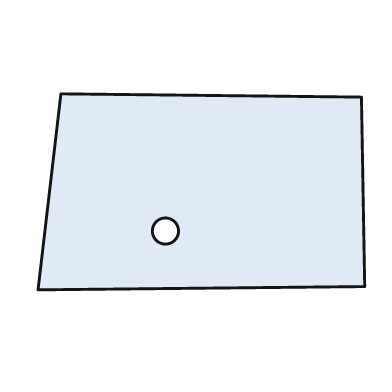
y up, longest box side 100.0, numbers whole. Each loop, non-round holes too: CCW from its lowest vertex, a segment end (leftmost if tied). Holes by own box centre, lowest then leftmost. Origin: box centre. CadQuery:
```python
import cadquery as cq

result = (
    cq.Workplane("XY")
    .moveTo(-50.0, -30.0)
    .lineTo(50.0, -29.0)
    .lineTo(49.0, 29.0)
    .lineTo(-43.0, 30.0)
    .close()
    .moveTo(-11.0, -12.0)
    .circle(4.0)
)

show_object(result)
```